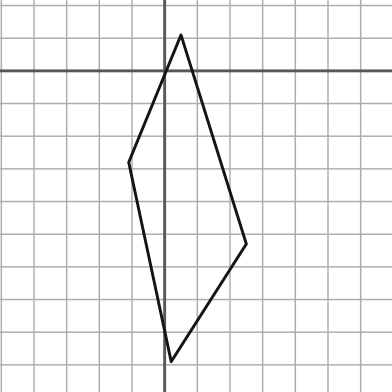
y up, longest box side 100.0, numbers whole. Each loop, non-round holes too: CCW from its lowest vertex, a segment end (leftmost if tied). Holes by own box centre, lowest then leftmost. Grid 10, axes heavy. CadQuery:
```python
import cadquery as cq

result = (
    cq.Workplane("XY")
    .moveTo(2.0, -89.0)
    .lineTo(25.0, -53.0)
    .lineTo(5.0, 11.0)
    .lineTo(-11.0, -28.0)
    .close()
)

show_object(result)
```